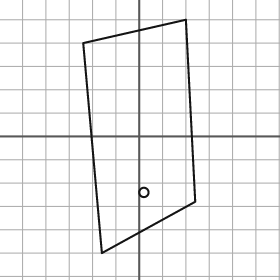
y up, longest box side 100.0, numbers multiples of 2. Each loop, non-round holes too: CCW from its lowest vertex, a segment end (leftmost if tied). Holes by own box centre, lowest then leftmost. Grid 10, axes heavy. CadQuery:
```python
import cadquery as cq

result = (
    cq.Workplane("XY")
    .moveTo(-16.0, -50.0)
    .lineTo(24.0, -28.0)
    .lineTo(20.0, 50.0)
    .lineTo(-24.0, 40.0)
    .close()
    .moveTo(2.0, -24.0)
    .circle(2.0)
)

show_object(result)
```